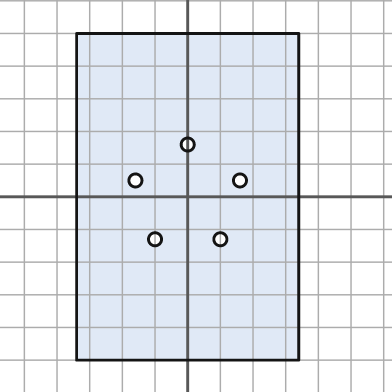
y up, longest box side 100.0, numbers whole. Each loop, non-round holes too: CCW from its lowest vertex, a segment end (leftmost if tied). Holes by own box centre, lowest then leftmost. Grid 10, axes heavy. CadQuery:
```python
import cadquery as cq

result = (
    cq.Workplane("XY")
    .moveTo(-34.0, -50.0)
    .lineTo(34.0, -50.0)
    .lineTo(34.0, 50.0)
    .lineTo(-34.0, 50.0)
    .close()
    .moveTo(-10.0, -13.0)
    .circle(2.0)
    .moveTo(10.0, -13.0)
    .circle(2.0)
    .moveTo(-16.0, 5.0)
    .circle(2.0)
    .moveTo(16.0, 5.0)
    .circle(2.0)
    .moveTo(0.0, 16.0)
    .circle(2.0)
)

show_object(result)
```